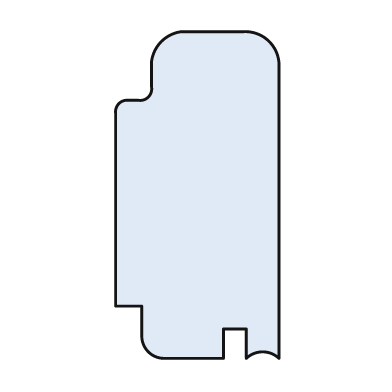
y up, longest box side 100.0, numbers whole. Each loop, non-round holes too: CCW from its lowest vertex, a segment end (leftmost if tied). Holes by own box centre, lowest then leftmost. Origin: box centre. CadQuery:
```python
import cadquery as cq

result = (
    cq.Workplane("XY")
    .moveTo(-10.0, -50.0)
    .lineTo(8.0, -50.0)
    .lineTo(8.0, -41.0)
    .lineTo(15.0, -41.0)
    .lineTo(15.0, -50.0)
    .threePointArc((20.0, -48.0), (25.0, -50.0))
    .lineTo(25.0, 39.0)
    .threePointArc((22.0, 47.0), (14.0, 50.0))
    .lineTo(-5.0, 50.0)
    .threePointArc((-11.0, 47.0), (-14.0, 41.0))
    .lineTo(-14.0, 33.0)
    .threePointArc((-15.0, 30.0), (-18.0, 29.0))
    .lineTo(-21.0, 29.0)
    .threePointArc((-24.0, 28.0), (-25.0, 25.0))
    .lineTo(-25.0, -34.0)
    .lineTo(-17.0, -34.0)
    .lineTo(-17.0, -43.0)
    .threePointArc((-15.0, -48.0), (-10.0, -50.0))
    .close()
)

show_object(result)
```